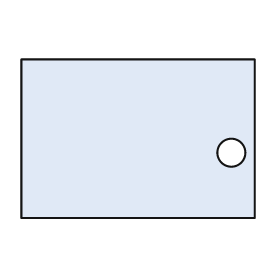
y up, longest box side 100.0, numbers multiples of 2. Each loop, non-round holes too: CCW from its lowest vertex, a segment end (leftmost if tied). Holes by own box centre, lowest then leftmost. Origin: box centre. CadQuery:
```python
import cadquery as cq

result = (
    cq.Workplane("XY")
    .moveTo(-50.0, -34.0)
    .lineTo(50.0, -34.0)
    .lineTo(50.0, 34.0)
    .lineTo(-50.0, 34.0)
    .close()
    .moveTo(40.0, -6.0)
    .circle(6.0)
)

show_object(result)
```